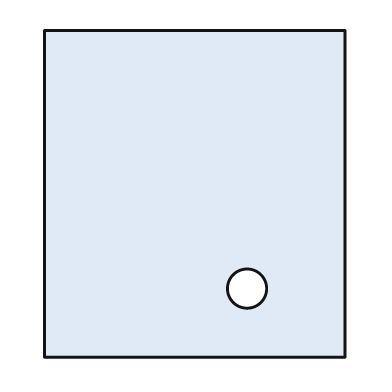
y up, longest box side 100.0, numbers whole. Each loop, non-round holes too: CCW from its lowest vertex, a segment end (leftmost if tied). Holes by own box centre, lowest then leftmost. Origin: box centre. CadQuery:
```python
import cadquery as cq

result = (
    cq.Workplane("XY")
    .moveTo(-46.0, -50.0)
    .lineTo(46.0, -50.0)
    .lineTo(46.0, 50.0)
    .lineTo(-46.0, 50.0)
    .close()
    .moveTo(16.0, -29.0)
    .circle(6.0)
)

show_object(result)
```